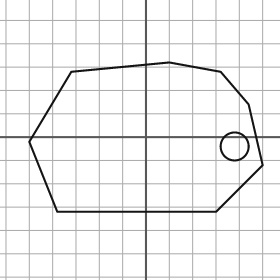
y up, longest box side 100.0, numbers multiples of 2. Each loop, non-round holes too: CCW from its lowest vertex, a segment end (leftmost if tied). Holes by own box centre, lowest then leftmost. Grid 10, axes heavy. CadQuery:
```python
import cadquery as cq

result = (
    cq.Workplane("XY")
    .moveTo(-38.0, -32.0)
    .lineTo(30.0, -32.0)
    .lineTo(50.0, -12.0)
    .lineTo(44.0, 14.0)
    .lineTo(32.0, 28.0)
    .lineTo(10.0, 32.0)
    .lineTo(-32.0, 28.0)
    .lineTo(-50.0, -2.0)
    .close()
    .moveTo(38.0, -4.0)
    .circle(6.0)
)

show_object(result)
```